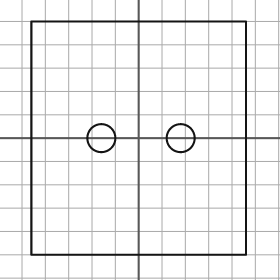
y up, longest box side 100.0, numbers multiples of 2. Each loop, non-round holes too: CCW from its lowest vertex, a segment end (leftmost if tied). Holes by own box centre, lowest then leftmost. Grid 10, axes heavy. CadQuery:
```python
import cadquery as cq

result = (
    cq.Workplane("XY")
    .moveTo(-46.0, -50.0)
    .lineTo(46.0, -50.0)
    .lineTo(46.0, 50.0)
    .lineTo(-46.0, 50.0)
    .close()
    .moveTo(-16.0, 0.0)
    .circle(6.0)
    .moveTo(18.0, 0.0)
    .circle(6.0)
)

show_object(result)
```